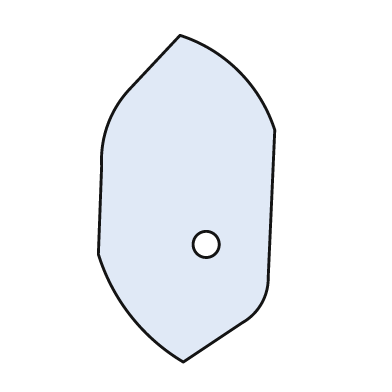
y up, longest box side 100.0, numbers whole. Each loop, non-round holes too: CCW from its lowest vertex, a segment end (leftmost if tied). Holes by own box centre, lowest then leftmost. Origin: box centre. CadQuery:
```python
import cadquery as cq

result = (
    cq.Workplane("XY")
    .moveTo(-1.0, -50.0)
    .lineTo(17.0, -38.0)
    .threePointArc((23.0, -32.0), (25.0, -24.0))
    .lineTo(27.0, 21.0)
    .threePointArc((16.0, 39.0), (-2.0, 50.0))
    .lineTo(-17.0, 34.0)
    .threePointArc((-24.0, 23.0), (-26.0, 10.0))
    .lineTo(-27.0, -17.0)
    .threePointArc((-17.0, -36.0), (-1.0, -50.0))
    .close()
    .moveTo(6.0, -14.0)
    .circle(4.0)
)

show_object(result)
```